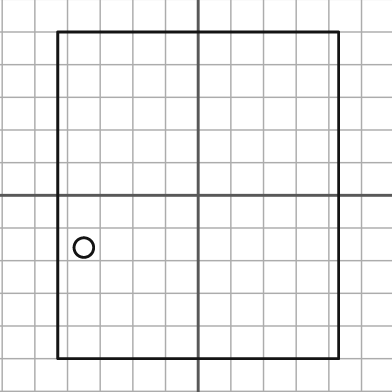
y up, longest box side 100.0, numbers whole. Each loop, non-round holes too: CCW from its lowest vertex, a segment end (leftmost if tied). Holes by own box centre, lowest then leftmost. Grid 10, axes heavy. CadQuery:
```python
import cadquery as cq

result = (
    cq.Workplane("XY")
    .moveTo(-43.0, -50.0)
    .lineTo(43.0, -50.0)
    .lineTo(43.0, 50.0)
    .lineTo(-43.0, 50.0)
    .close()
    .moveTo(-35.0, -16.0)
    .circle(3.0)
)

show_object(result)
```